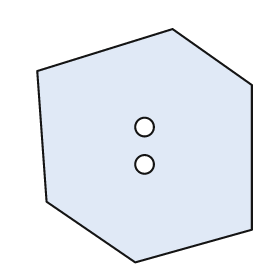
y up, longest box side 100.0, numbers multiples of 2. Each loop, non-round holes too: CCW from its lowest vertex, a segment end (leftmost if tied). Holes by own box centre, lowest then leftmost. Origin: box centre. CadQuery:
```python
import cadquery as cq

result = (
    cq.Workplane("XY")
    .moveTo(-4.0, -50.0)
    .lineTo(46.0, -36.0)
    .lineTo(46.0, 26.0)
    .lineTo(12.0, 50.0)
    .lineTo(-46.0, 32.0)
    .lineTo(-42.0, -24.0)
    .close()
    .moveTo(0.0, -8.0)
    .circle(4.0)
    .moveTo(0.0, 8.0)
    .circle(4.0)
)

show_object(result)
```